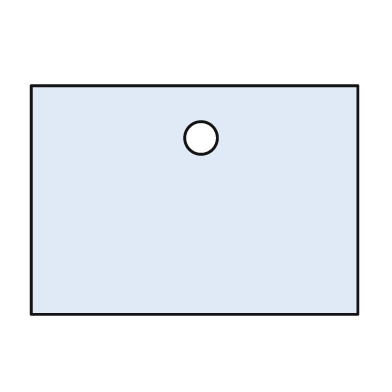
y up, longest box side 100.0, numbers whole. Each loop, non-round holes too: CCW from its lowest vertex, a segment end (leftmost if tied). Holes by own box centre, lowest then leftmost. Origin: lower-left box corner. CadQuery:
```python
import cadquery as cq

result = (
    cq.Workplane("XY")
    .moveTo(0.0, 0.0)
    .lineTo(100.0, 0.0)
    .lineTo(100.0, 70.0)
    .lineTo(0.0, 70.0)
    .close()
    .moveTo(52.0, 54.0)
    .circle(5.0)
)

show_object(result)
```